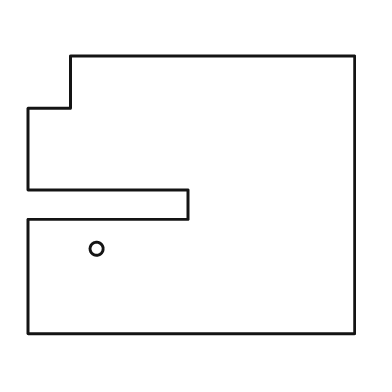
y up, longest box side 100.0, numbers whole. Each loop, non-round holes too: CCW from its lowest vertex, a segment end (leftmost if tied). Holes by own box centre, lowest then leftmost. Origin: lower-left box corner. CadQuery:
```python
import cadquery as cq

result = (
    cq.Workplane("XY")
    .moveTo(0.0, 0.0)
    .lineTo(100.0, 0.0)
    .lineTo(100.0, 85.0)
    .lineTo(13.0, 85.0)
    .lineTo(13.0, 69.0)
    .lineTo(0.0, 69.0)
    .lineTo(0.0, 44.0)
    .lineTo(49.0, 44.0)
    .lineTo(49.0, 35.0)
    .lineTo(0.0, 35.0)
    .close()
    .moveTo(21.0, 26.0)
    .circle(2.0)
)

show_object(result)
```